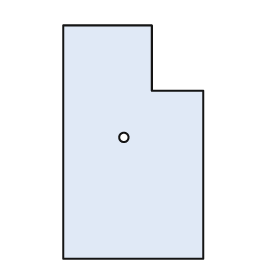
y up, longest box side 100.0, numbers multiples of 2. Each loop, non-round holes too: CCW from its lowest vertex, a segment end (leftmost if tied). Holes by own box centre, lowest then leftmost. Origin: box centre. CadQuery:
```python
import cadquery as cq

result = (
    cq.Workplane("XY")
    .moveTo(-30.0, -50.0)
    .lineTo(30.0, -50.0)
    .lineTo(30.0, 22.0)
    .lineTo(8.0, 22.0)
    .lineTo(8.0, 50.0)
    .lineTo(-30.0, 50.0)
    .close()
    .moveTo(-4.0, 2.0)
    .circle(2.0)
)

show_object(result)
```